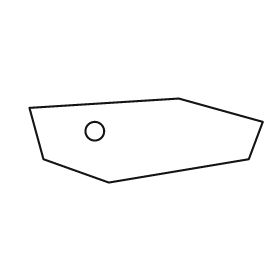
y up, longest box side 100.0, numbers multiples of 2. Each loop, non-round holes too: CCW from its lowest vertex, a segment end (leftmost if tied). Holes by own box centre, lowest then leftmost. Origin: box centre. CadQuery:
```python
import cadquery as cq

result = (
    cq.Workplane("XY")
    .moveTo(-16.0, -18.0)
    .lineTo(44.0, -8.0)
    .lineTo(50.0, 8.0)
    .lineTo(14.0, 18.0)
    .lineTo(-50.0, 14.0)
    .lineTo(-44.0, -8.0)
    .close()
    .moveTo(-22.0, 4.0)
    .circle(4.0)
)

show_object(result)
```